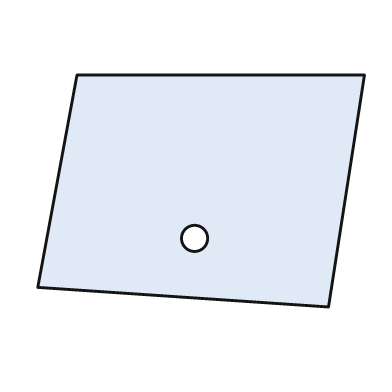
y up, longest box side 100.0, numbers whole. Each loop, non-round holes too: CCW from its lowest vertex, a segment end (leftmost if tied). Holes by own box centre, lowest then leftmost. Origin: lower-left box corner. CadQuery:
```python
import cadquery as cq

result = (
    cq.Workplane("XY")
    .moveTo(89.0, 0.0)
    .lineTo(100.0, 71.0)
    .lineTo(12.0, 71.0)
    .lineTo(0.0, 6.0)
    .close()
    .moveTo(48.0, 21.0)
    .circle(4.0)
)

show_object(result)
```